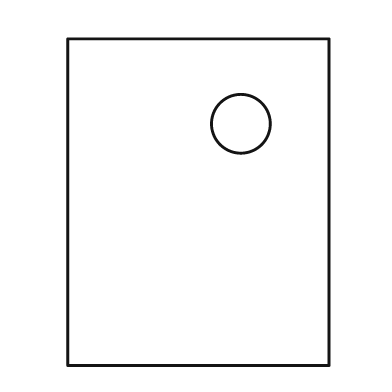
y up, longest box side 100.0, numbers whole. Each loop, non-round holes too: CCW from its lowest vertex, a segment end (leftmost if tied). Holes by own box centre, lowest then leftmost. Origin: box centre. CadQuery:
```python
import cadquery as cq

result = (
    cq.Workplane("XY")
    .moveTo(-40.0, -50.0)
    .lineTo(40.0, -50.0)
    .lineTo(40.0, 50.0)
    .lineTo(-40.0, 50.0)
    .close()
    .moveTo(13.0, 24.0)
    .circle(9.0)
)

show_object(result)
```